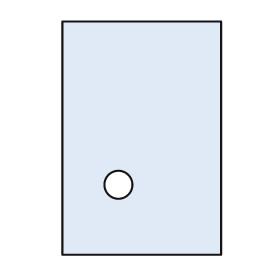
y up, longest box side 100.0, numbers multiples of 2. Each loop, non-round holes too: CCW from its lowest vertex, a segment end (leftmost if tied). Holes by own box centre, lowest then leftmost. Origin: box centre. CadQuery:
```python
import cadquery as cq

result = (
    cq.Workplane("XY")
    .moveTo(-34.0, -50.0)
    .lineTo(34.0, -50.0)
    .lineTo(34.0, 50.0)
    .lineTo(-34.0, 50.0)
    .close()
    .moveTo(-10.0, -20.0)
    .circle(6.0)
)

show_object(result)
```